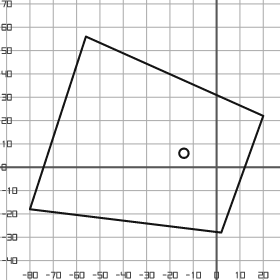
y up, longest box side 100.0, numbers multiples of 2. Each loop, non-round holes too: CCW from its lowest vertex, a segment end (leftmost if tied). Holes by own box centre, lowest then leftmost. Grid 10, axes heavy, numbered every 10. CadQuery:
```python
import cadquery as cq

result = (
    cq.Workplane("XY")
    .moveTo(2.0, -28.0)
    .lineTo(20.0, 22.0)
    .lineTo(-56.0, 56.0)
    .lineTo(-80.0, -18.0)
    .close()
    .moveTo(-14.0, 6.0)
    .circle(2.0)
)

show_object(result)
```